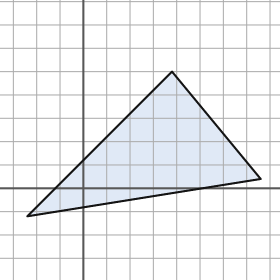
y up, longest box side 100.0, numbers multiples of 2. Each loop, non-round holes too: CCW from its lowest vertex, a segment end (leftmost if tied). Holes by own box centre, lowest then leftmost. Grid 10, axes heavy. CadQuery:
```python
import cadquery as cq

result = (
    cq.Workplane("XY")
    .moveTo(-24.0, -12.0)
    .lineTo(76.0, 4.0)
    .lineTo(38.0, 50.0)
    .close()
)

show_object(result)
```